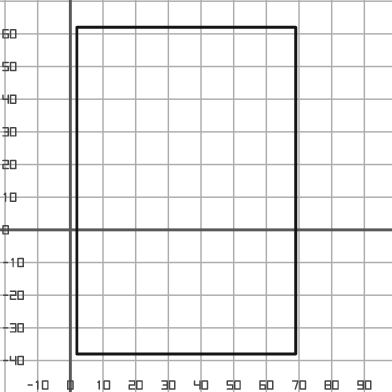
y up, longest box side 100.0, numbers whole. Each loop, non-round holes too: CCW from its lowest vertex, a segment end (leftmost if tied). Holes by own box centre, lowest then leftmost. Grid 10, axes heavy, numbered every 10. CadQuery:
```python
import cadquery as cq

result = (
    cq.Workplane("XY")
    .moveTo(2.0, -38.0)
    .lineTo(69.0, -38.0)
    .lineTo(69.0, 62.0)
    .lineTo(2.0, 62.0)
    .close()
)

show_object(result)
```